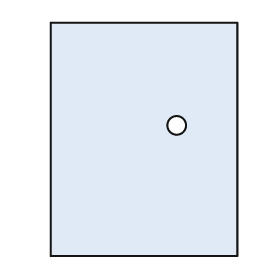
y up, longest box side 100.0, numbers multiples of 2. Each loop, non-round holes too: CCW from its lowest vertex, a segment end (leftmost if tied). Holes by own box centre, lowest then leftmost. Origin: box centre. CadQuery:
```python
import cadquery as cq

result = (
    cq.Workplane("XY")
    .moveTo(-40.0, -50.0)
    .lineTo(40.0, -50.0)
    .lineTo(40.0, 50.0)
    .lineTo(-40.0, 50.0)
    .close()
    .moveTo(14.0, 6.0)
    .circle(4.0)
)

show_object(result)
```